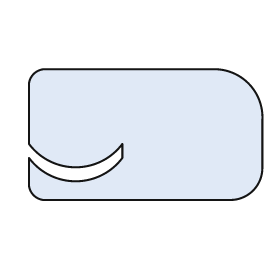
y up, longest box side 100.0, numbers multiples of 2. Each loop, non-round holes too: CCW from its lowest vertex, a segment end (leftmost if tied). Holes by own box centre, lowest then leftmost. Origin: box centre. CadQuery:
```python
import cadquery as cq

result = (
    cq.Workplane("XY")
    .moveTo(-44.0, -28.0)
    .lineTo(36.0, -28.0)
    .threePointArc((46.0, -24.0), (50.0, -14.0))
    .lineTo(50.0, 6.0)
    .threePointArc((44.0, 22.0), (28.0, 28.0))
    .lineTo(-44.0, 28.0)
    .threePointArc((-48.0, 26.0), (-50.0, 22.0))
    .lineTo(-50.0, -4.0)
    .threePointArc((-30.0, -14.0), (-10.0, -4.0))
    .lineTo(-10.0, -10.0)
    .threePointArc((-30.0, -20.0), (-50.0, -10.0))
    .lineTo(-50.0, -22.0)
    .threePointArc((-48.0, -26.0), (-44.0, -28.0))
    .close()
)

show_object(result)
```